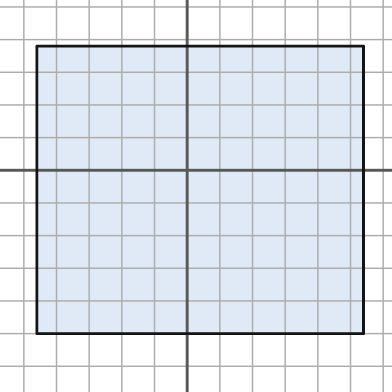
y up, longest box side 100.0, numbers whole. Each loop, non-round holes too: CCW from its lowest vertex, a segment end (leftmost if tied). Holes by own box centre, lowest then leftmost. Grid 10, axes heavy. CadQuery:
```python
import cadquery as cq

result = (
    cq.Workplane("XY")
    .moveTo(-46.0, -50.0)
    .lineTo(54.0, -50.0)
    .lineTo(54.0, 38.0)
    .lineTo(-46.0, 38.0)
    .close()
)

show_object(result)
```